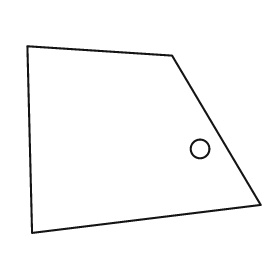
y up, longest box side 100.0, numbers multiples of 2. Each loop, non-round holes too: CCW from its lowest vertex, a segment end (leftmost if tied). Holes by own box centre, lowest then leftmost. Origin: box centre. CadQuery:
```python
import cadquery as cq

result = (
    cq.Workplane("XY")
    .moveTo(-48.0, -40.0)
    .lineTo(50.0, -28.0)
    .lineTo(12.0, 36.0)
    .lineTo(-50.0, 40.0)
    .close()
    .moveTo(24.0, -4.0)
    .circle(4.0)
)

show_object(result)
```